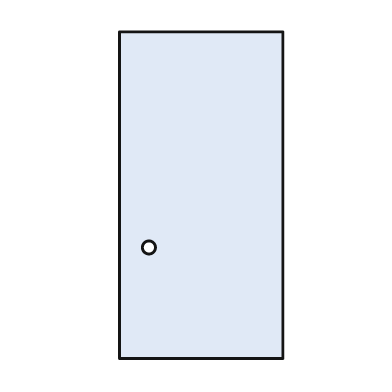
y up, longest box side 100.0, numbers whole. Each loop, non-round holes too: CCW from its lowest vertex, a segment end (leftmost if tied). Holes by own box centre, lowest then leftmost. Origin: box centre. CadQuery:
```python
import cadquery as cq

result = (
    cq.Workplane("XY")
    .moveTo(-25.0, -50.0)
    .lineTo(25.0, -50.0)
    .lineTo(25.0, 50.0)
    .lineTo(-25.0, 50.0)
    .close()
    .moveTo(-16.0, -16.0)
    .circle(2.0)
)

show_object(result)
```